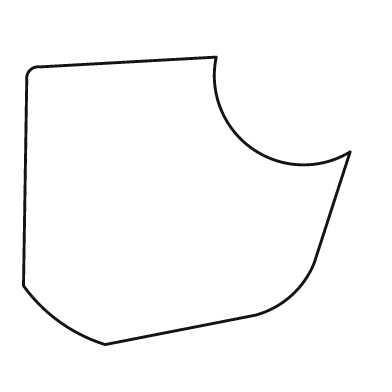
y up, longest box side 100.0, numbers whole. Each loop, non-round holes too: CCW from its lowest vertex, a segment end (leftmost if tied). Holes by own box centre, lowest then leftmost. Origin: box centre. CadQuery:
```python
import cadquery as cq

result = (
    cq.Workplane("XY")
    .moveTo(-25.0, -44.0)
    .lineTo(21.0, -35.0)
    .threePointArc((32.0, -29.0), (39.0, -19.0))
    .lineTo(50.0, 15.0)
    .threePointArc((20.0, 16.0), (9.0, 44.0))
    .lineTo(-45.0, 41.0)
    .threePointArc((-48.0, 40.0), (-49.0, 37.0))
    .lineTo(-50.0, -26.0)
    .threePointArc((-39.0, -37.0), (-25.0, -44.0))
    .close()
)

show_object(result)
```